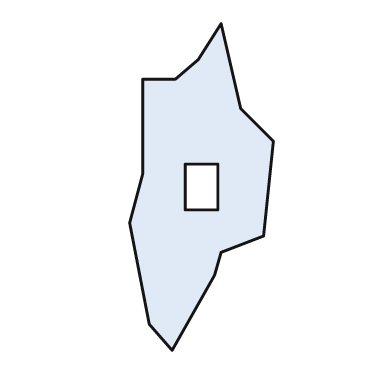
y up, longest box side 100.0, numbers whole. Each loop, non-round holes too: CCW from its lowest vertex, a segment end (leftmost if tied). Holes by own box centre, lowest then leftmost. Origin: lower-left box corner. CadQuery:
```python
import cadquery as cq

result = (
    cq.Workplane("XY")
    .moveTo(13.0, 0.0)
    .lineTo(26.0, 23.0)
    .lineTo(28.0, 30.0)
    .lineTo(41.0, 35.0)
    .lineTo(44.0, 64.0)
    .lineTo(34.0, 74.0)
    .lineTo(28.0, 100.0)
    .lineTo(21.0, 89.0)
    .lineTo(14.0, 83.0)
    .lineTo(4.0, 83.0)
    .lineTo(4.0, 54.0)
    .lineTo(0.0, 39.0)
    .lineTo(6.0, 8.0)
    .close()
    .moveTo(17.0, 43.0)
    .lineTo(27.0, 43.0)
    .lineTo(27.0, 57.0)
    .lineTo(17.0, 57.0)
    .close()
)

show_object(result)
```